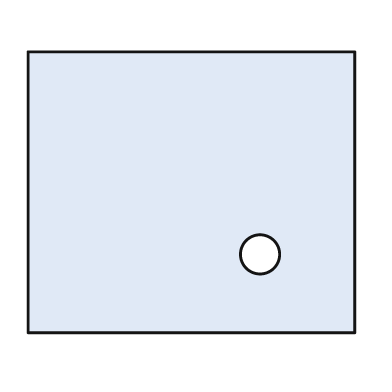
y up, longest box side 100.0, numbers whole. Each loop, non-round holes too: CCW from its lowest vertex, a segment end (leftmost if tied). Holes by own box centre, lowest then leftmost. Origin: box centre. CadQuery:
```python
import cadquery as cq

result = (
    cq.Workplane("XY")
    .moveTo(-50.0, -43.0)
    .lineTo(50.0, -43.0)
    .lineTo(50.0, 43.0)
    .lineTo(-50.0, 43.0)
    .close()
    .moveTo(21.0, -19.0)
    .circle(6.0)
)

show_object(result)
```